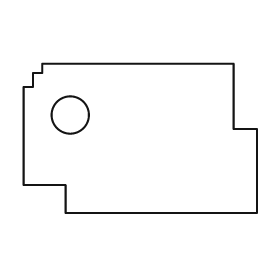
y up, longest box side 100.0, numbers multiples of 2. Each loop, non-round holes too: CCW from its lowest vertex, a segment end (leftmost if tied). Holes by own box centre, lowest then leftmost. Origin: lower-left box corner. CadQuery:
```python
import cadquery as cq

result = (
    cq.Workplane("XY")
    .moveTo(18.0, 0.0)
    .lineTo(100.0, 0.0)
    .lineTo(100.0, 36.0)
    .lineTo(90.0, 36.0)
    .lineTo(90.0, 64.0)
    .lineTo(8.0, 64.0)
    .lineTo(8.0, 60.0)
    .lineTo(4.0, 60.0)
    .lineTo(4.0, 54.0)
    .lineTo(0.0, 54.0)
    .lineTo(0.0, 12.0)
    .lineTo(18.0, 12.0)
    .close()
    .moveTo(20.0, 42.0)
    .circle(8.0)
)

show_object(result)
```